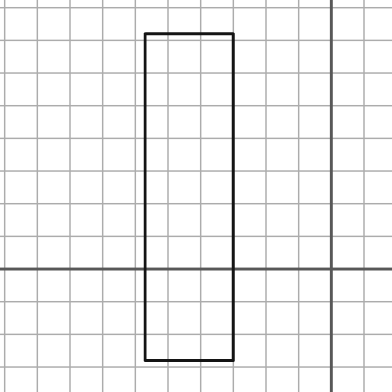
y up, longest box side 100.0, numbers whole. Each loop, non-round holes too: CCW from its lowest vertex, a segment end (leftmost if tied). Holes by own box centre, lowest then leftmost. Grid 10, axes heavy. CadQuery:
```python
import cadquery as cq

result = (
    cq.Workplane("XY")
    .moveTo(-57.0, -28.0)
    .lineTo(-30.0, -28.0)
    .lineTo(-30.0, 72.0)
    .lineTo(-57.0, 72.0)
    .close()
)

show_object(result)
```